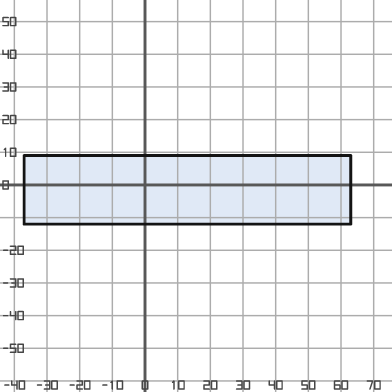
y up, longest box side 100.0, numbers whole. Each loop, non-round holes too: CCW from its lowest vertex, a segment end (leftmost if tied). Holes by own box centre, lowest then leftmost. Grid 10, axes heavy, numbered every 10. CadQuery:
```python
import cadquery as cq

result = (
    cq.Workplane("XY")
    .moveTo(-37.0, -12.0)
    .lineTo(63.0, -12.0)
    .lineTo(63.0, 9.0)
    .lineTo(-37.0, 9.0)
    .close()
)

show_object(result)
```